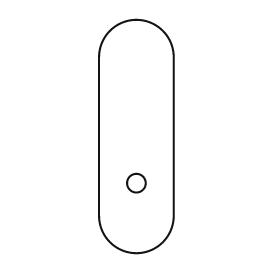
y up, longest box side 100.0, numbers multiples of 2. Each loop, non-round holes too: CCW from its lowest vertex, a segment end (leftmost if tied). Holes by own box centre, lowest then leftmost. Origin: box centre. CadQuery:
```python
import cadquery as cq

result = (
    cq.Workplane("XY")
    .moveTo(-16.0, -34.0)
    .threePointArc((0.0, -50.0), (16.0, -34.0))
    .lineTo(16.0, 34.0)
    .threePointArc((0.0, 50.0), (-16.0, 34.0))
    .close()
    .moveTo(0.0, -20.0)
    .circle(4.0)
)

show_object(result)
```